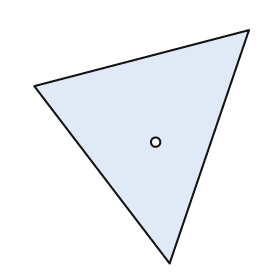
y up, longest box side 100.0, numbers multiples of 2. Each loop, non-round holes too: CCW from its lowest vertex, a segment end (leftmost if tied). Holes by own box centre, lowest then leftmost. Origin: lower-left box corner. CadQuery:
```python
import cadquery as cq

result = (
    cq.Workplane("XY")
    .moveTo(58.0, 0.0)
    .lineTo(92.0, 100.0)
    .lineTo(0.0, 76.0)
    .close()
    .moveTo(52.0, 52.0)
    .circle(2.0)
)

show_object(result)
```